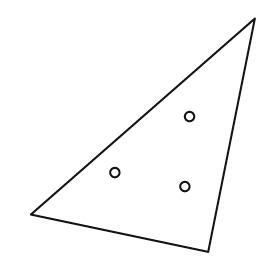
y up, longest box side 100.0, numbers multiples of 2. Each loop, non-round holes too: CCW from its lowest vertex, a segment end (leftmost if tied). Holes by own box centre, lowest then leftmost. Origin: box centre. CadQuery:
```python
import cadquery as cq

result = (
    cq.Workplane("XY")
    .moveTo(28.0, -50.0)
    .lineTo(48.0, 50.0)
    .lineTo(-48.0, -34.0)
    .close()
    .moveTo(18.0, -22.0)
    .circle(2.0)
    .moveTo(-12.0, -16.0)
    .circle(2.0)
    .moveTo(20.0, 8.0)
    .circle(2.0)
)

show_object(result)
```